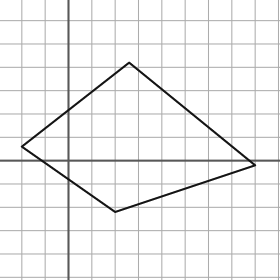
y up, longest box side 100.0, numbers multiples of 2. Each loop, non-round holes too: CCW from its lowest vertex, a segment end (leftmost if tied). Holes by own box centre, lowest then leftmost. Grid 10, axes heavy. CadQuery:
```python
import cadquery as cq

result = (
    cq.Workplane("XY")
    .moveTo(20.0, -22.0)
    .lineTo(80.0, -2.0)
    .lineTo(26.0, 42.0)
    .lineTo(-20.0, 6.0)
    .close()
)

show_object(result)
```